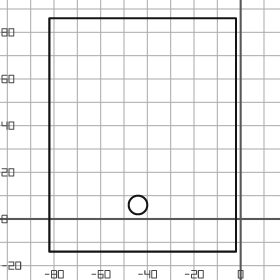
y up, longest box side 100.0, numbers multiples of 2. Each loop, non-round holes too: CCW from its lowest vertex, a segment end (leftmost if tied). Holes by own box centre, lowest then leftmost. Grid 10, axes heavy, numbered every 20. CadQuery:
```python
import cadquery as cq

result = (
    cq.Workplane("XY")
    .moveTo(-82.0, -14.0)
    .lineTo(-2.0, -14.0)
    .lineTo(-2.0, 86.0)
    .lineTo(-82.0, 86.0)
    .close()
    .moveTo(-44.0, 6.0)
    .circle(4.0)
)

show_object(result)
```